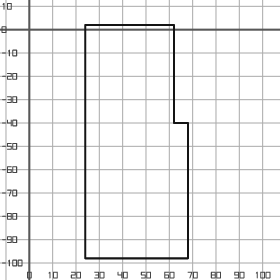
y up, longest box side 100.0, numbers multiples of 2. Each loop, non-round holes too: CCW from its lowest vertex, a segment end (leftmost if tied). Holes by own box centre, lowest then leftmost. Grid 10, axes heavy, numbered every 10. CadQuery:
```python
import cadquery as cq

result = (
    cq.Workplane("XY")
    .moveTo(24.0, -98.0)
    .lineTo(68.0, -98.0)
    .lineTo(68.0, -40.0)
    .lineTo(62.0, -40.0)
    .lineTo(62.0, 2.0)
    .lineTo(24.0, 2.0)
    .close()
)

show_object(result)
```